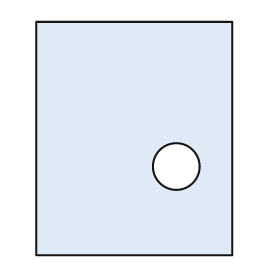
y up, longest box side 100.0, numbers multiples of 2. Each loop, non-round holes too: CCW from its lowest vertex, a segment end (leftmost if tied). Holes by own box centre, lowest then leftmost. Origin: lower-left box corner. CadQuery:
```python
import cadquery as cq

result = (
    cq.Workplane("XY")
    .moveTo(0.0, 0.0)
    .lineTo(84.0, 0.0)
    .lineTo(84.0, 100.0)
    .lineTo(0.0, 100.0)
    .close()
    .moveTo(60.0, 38.0)
    .circle(10.0)
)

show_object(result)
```